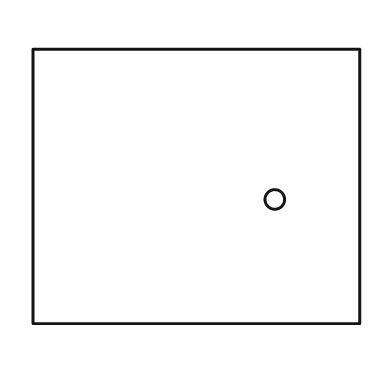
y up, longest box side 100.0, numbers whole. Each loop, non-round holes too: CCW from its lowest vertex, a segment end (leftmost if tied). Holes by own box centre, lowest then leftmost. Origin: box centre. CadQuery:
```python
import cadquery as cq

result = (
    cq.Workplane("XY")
    .moveTo(-50.0, -42.0)
    .lineTo(50.0, -42.0)
    .lineTo(50.0, 42.0)
    .lineTo(-50.0, 42.0)
    .close()
    .moveTo(24.0, -4.0)
    .circle(3.0)
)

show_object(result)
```